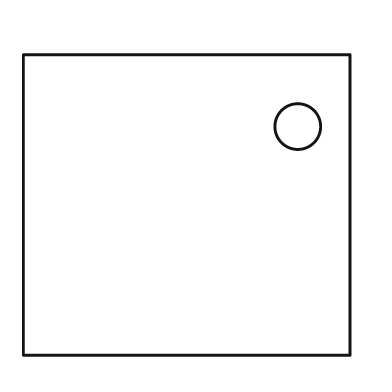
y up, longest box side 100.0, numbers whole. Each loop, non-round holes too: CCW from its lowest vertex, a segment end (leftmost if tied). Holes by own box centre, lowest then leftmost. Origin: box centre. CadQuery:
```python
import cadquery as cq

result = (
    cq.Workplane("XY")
    .moveTo(-50.0, -46.0)
    .lineTo(50.0, -46.0)
    .lineTo(50.0, 46.0)
    .lineTo(-50.0, 46.0)
    .close()
    .moveTo(34.0, 24.0)
    .circle(7.0)
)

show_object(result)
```